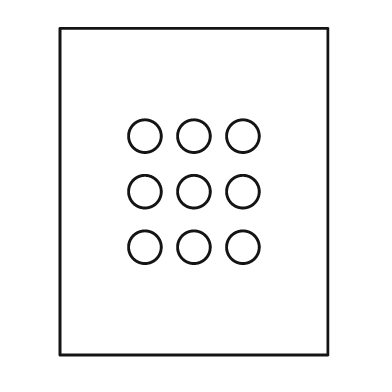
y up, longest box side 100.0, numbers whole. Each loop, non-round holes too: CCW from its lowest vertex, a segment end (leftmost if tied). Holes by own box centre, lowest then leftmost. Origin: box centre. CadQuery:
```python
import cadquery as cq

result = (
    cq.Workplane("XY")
    .moveTo(-41.0, -50.0)
    .lineTo(41.0, -50.0)
    .lineTo(41.0, 50.0)
    .lineTo(-41.0, 50.0)
    .close()
    .moveTo(-15.0, -17.0)
    .circle(5.0)
    .moveTo(0.0, -17.0)
    .circle(5.0)
    .moveTo(15.0, -17.0)
    .circle(5.0)
    .moveTo(-15.0, 0.0)
    .circle(5.0)
    .moveTo(0.0, 0.0)
    .circle(5.0)
    .moveTo(15.0, 0.0)
    .circle(5.0)
    .moveTo(-15.0, 17.0)
    .circle(5.0)
    .moveTo(0.0, 17.0)
    .circle(5.0)
    .moveTo(15.0, 17.0)
    .circle(5.0)
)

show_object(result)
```